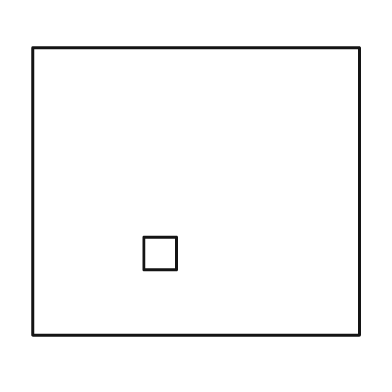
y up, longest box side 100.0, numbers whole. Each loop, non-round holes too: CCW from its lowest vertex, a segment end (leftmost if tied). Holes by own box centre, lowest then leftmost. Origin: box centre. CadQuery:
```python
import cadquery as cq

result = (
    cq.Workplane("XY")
    .moveTo(-50.0, -44.0)
    .lineTo(50.0, -44.0)
    .lineTo(50.0, 44.0)
    .lineTo(-50.0, 44.0)
    .close()
    .moveTo(-16.0, -24.0)
    .lineTo(-6.0, -24.0)
    .lineTo(-6.0, -14.0)
    .lineTo(-16.0, -14.0)
    .close()
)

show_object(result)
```